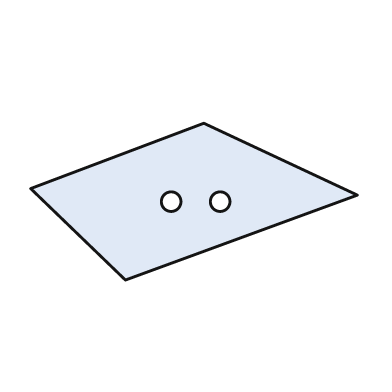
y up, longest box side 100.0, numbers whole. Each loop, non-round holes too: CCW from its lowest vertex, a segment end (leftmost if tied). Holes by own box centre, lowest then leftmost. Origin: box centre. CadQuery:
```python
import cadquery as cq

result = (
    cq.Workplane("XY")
    .moveTo(-21.0, -24.0)
    .lineTo(50.0, 2.0)
    .lineTo(3.0, 24.0)
    .lineTo(-50.0, 4.0)
    .close()
    .moveTo(-7.0, 0.0)
    .circle(3.0)
    .moveTo(8.0, 0.0)
    .circle(3.0)
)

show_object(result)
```